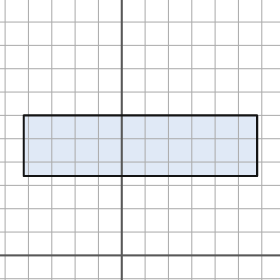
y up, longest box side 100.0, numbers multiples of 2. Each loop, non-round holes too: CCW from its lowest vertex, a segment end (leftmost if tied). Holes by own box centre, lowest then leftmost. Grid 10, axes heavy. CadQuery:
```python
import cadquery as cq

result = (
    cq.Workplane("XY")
    .moveTo(-42.0, 34.0)
    .lineTo(58.0, 34.0)
    .lineTo(58.0, 60.0)
    .lineTo(-42.0, 60.0)
    .close()
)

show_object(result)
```